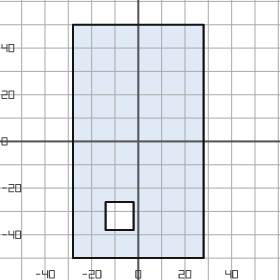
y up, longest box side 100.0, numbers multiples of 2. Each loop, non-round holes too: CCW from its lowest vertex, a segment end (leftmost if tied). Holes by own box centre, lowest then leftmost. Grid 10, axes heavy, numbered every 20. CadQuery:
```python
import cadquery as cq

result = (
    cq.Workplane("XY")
    .moveTo(-28.0, -50.0)
    .lineTo(28.0, -50.0)
    .lineTo(28.0, 50.0)
    .lineTo(-28.0, 50.0)
    .close()
    .moveTo(-14.0, -38.0)
    .lineTo(-2.0, -38.0)
    .lineTo(-2.0, -26.0)
    .lineTo(-14.0, -26.0)
    .close()
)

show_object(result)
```